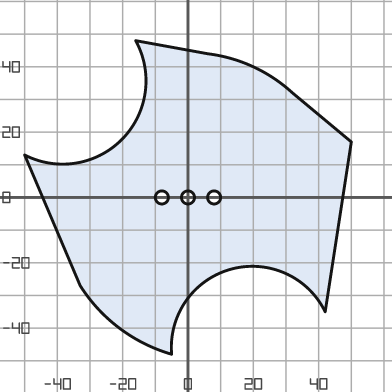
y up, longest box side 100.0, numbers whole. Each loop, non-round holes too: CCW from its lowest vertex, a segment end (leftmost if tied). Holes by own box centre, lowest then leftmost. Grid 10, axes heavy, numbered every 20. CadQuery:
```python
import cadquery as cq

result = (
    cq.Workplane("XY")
    .moveTo(-5.0, -48.0)
    .threePointArc((13.0, -22.0), (42.0, -35.0))
    .lineTo(50.0, 17.0)
    .lineTo(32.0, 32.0)
    .threePointArc((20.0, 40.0), (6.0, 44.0))
    .lineTo(-16.0, 48.0)
    .threePointArc((-20.0, 18.0), (-50.0, 13.0))
    .lineTo(-33.0, -27.0)
    .threePointArc((-21.0, -40.0), (-5.0, -48.0))
    .close()
    .moveTo(-8.0, 0.0)
    .circle(2.0)
    .moveTo(0.0, 0.0)
    .circle(2.0)
    .moveTo(8.0, 0.0)
    .circle(2.0)
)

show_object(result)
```